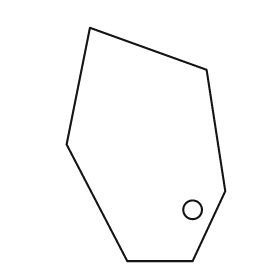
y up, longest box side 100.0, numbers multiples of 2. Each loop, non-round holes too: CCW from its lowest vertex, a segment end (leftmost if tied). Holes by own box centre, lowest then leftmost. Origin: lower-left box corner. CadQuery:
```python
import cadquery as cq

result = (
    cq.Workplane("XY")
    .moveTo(26.0, 0.0)
    .lineTo(54.0, 0.0)
    .lineTo(68.0, 30.0)
    .lineTo(60.0, 82.0)
    .lineTo(10.0, 100.0)
    .lineTo(0.0, 50.0)
    .close()
    .moveTo(54.0, 22.0)
    .circle(4.0)
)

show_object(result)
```